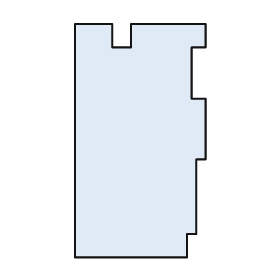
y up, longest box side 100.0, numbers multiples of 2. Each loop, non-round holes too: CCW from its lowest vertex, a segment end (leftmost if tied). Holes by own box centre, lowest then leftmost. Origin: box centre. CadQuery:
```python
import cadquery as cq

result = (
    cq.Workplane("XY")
    .moveTo(-28.0, -50.0)
    .lineTo(20.0, -50.0)
    .lineTo(20.0, -40.0)
    .lineTo(24.0, -40.0)
    .lineTo(24.0, -8.0)
    .lineTo(28.0, -8.0)
    .lineTo(28.0, 18.0)
    .lineTo(22.0, 18.0)
    .lineTo(22.0, 40.0)
    .lineTo(28.0, 40.0)
    .lineTo(28.0, 50.0)
    .lineTo(-4.0, 50.0)
    .lineTo(-4.0, 40.0)
    .lineTo(-12.0, 40.0)
    .lineTo(-12.0, 50.0)
    .lineTo(-28.0, 50.0)
    .close()
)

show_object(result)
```